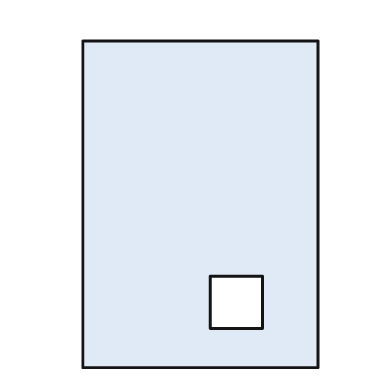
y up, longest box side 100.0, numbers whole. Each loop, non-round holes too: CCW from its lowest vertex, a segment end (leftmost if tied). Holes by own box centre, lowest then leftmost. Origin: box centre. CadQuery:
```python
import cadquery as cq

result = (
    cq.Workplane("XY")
    .moveTo(-36.0, -50.0)
    .lineTo(36.0, -50.0)
    .lineTo(36.0, 50.0)
    .lineTo(-36.0, 50.0)
    .close()
    .moveTo(3.0, -38.0)
    .lineTo(19.0, -38.0)
    .lineTo(19.0, -22.0)
    .lineTo(3.0, -22.0)
    .close()
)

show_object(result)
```